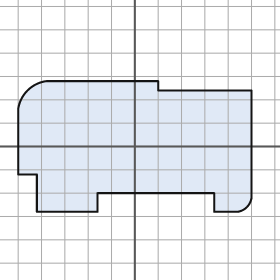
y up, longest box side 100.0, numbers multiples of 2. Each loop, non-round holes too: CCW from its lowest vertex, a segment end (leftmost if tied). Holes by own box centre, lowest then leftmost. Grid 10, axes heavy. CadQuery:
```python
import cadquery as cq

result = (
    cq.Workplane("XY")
    .moveTo(-42.0, -28.0)
    .lineTo(-16.0, -28.0)
    .lineTo(-16.0, -20.0)
    .lineTo(34.0, -20.0)
    .lineTo(34.0, -28.0)
    .lineTo(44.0, -28.0)
    .threePointArc((48.0, -26.0), (50.0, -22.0))
    .lineTo(50.0, 24.0)
    .lineTo(10.0, 24.0)
    .lineTo(10.0, 28.0)
    .lineTo(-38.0, 28.0)
    .threePointArc((-46.0, 24.0), (-50.0, 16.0))
    .lineTo(-50.0, -12.0)
    .lineTo(-42.0, -12.0)
    .close()
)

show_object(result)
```